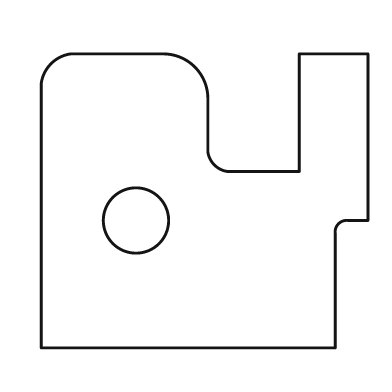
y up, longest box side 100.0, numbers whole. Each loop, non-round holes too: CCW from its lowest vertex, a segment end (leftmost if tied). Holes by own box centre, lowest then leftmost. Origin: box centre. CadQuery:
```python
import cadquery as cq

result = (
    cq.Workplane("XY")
    .moveTo(-50.0, -45.0)
    .lineTo(40.0, -45.0)
    .lineTo(40.0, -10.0)
    .threePointArc((41.0, -7.0), (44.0, -6.0))
    .lineTo(50.0, -6.0)
    .lineTo(50.0, 45.0)
    .lineTo(29.0, 45.0)
    .lineTo(29.0, 9.0)
    .lineTo(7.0, 9.0)
    .threePointArc((3.0, 11.0), (1.0, 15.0))
    .lineTo(1.0, 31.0)
    .threePointArc((-3.0, 41.0), (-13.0, 45.0))
    .lineTo(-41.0, 45.0)
    .threePointArc((-47.0, 42.0), (-50.0, 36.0))
    .close()
    .moveTo(-21.0, -6.0)
    .circle(10.0)
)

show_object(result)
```